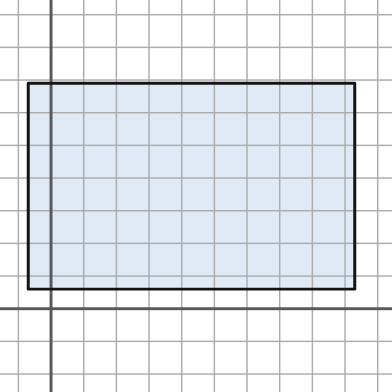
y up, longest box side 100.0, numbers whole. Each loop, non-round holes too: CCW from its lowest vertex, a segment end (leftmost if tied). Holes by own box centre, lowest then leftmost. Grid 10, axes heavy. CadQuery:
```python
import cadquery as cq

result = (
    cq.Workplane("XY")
    .moveTo(-7.0, 6.0)
    .lineTo(93.0, 6.0)
    .lineTo(93.0, 69.0)
    .lineTo(-7.0, 69.0)
    .close()
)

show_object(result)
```